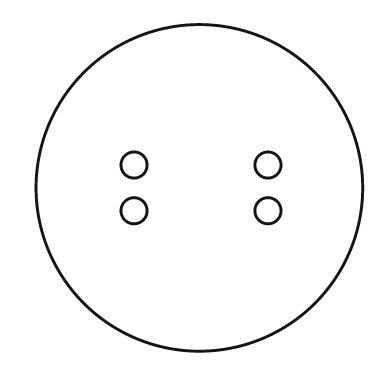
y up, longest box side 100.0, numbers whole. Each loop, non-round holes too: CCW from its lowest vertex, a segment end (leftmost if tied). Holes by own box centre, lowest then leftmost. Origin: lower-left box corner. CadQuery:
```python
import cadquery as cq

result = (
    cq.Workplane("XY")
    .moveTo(50.0, 50.0)
    .circle(50.0)
    .moveTo(30.0, 43.0)
    .circle(4.0)
    .moveTo(71.0, 43.0)
    .circle(4.0)
    .moveTo(30.0, 57.0)
    .circle(4.0)
    .moveTo(71.0, 57.0)
    .circle(4.0)
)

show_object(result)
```